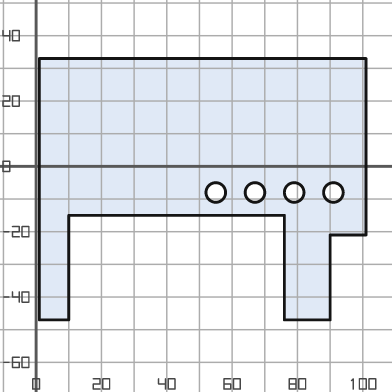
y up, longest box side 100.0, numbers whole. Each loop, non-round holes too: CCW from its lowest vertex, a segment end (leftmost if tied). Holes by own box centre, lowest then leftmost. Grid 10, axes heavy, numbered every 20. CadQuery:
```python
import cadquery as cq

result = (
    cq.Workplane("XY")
    .moveTo(1.0, -47.0)
    .lineTo(10.0, -47.0)
    .lineTo(10.0, -15.0)
    .lineTo(76.0, -15.0)
    .lineTo(76.0, -47.0)
    .lineTo(90.0, -47.0)
    .lineTo(90.0, -21.0)
    .lineTo(101.0, -21.0)
    .lineTo(101.0, 33.0)
    .lineTo(1.0, 33.0)
    .close()
    .moveTo(55.0, -8.0)
    .circle(3.0)
    .moveTo(67.0, -8.0)
    .circle(3.0)
    .moveTo(79.0, -8.0)
    .circle(3.0)
    .moveTo(91.0, -8.0)
    .circle(3.0)
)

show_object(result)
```